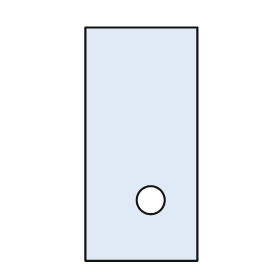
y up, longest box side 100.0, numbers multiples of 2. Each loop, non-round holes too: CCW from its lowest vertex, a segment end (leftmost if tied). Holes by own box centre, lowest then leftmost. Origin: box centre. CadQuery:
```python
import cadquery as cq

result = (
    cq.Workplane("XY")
    .moveTo(-24.0, -50.0)
    .lineTo(24.0, -50.0)
    .lineTo(24.0, 50.0)
    .lineTo(-24.0, 50.0)
    .close()
    .moveTo(4.0, -24.0)
    .circle(6.0)
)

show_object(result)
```